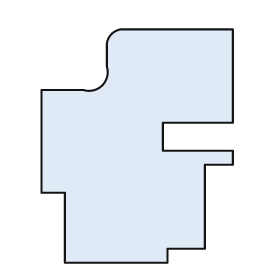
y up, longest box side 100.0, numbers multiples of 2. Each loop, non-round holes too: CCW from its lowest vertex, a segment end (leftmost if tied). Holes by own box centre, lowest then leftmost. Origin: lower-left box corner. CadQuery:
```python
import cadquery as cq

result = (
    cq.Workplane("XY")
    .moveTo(10.0, 0.0)
    .lineTo(54.0, 0.0)
    .lineTo(54.0, 6.0)
    .lineTo(70.0, 6.0)
    .lineTo(70.0, 42.0)
    .lineTo(82.0, 42.0)
    .lineTo(82.0, 48.0)
    .lineTo(52.0, 48.0)
    .lineTo(52.0, 60.0)
    .lineTo(82.0, 60.0)
    .lineTo(82.0, 100.0)
    .lineTo(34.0, 100.0)
    .threePointArc((30.0, 98.0), (28.0, 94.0))
    .lineTo(28.0, 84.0)
    .threePointArc((26.0, 76.0), (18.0, 74.0))
    .lineTo(0.0, 74.0)
    .lineTo(0.0, 30.0)
    .lineTo(10.0, 30.0)
    .close()
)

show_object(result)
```